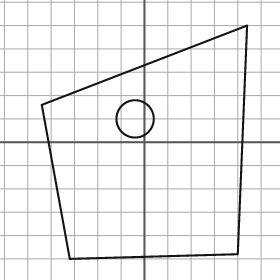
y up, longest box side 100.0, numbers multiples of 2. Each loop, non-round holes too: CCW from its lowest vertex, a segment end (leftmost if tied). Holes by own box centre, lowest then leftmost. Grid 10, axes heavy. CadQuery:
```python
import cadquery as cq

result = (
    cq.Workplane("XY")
    .moveTo(-32.0, -50.0)
    .lineTo(40.0, -48.0)
    .lineTo(44.0, 50.0)
    .lineTo(-44.0, 16.0)
    .close()
    .moveTo(-4.0, 10.0)
    .circle(8.0)
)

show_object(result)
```